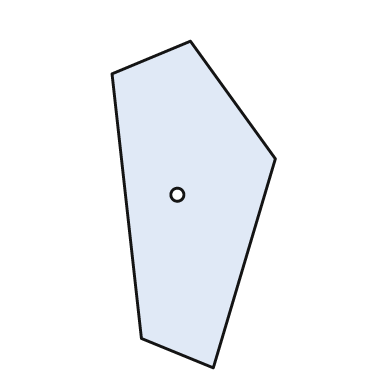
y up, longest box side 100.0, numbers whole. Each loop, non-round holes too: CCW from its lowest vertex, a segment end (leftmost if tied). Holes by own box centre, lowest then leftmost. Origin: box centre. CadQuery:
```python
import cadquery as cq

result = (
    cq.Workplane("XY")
    .moveTo(6.0, -50.0)
    .lineTo(25.0, 14.0)
    .lineTo(-1.0, 50.0)
    .lineTo(-25.0, 40.0)
    .lineTo(-16.0, -41.0)
    .close()
    .moveTo(-5.0, 3.0)
    .circle(2.0)
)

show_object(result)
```